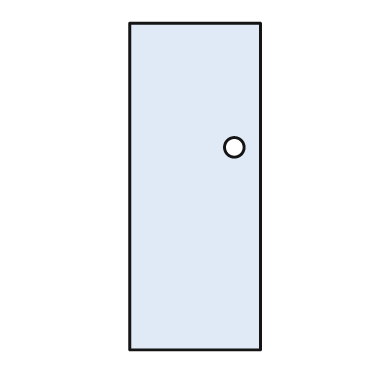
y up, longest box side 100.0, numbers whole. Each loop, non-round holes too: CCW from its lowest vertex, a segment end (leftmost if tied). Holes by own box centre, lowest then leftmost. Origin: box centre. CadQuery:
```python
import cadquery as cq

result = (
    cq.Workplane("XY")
    .moveTo(-20.0, -50.0)
    .lineTo(20.0, -50.0)
    .lineTo(20.0, 50.0)
    .lineTo(-20.0, 50.0)
    .close()
    .moveTo(12.0, 12.0)
    .circle(3.0)
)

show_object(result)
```